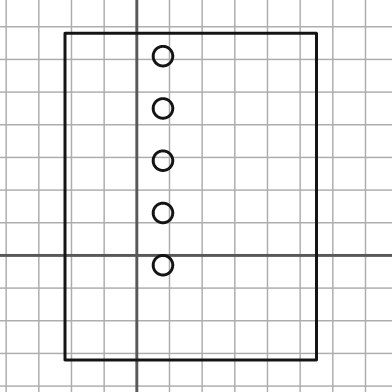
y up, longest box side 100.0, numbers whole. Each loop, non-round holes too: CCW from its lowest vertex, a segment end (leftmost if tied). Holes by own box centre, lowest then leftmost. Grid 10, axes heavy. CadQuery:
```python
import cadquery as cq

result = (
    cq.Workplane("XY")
    .moveTo(-22.0, -32.0)
    .lineTo(55.0, -32.0)
    .lineTo(55.0, 68.0)
    .lineTo(-22.0, 68.0)
    .close()
    .moveTo(8.0, -3.0)
    .circle(3.0)
    .moveTo(8.0, 13.0)
    .circle(3.0)
    .moveTo(8.0, 29.0)
    .circle(3.0)
    .moveTo(8.0, 45.0)
    .circle(3.0)
    .moveTo(8.0, 61.0)
    .circle(3.0)
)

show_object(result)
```